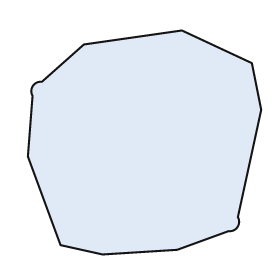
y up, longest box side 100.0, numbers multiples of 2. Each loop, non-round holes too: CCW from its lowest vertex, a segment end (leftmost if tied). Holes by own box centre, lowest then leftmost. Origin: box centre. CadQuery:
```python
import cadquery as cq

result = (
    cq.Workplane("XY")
    .moveTo(-18.0, -48.0)
    .lineTo(14.0, -46.0)
    .lineTo(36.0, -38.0)
    .threePointArc((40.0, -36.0), (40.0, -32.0))
    .lineTo(50.0, 14.0)
    .lineTo(46.0, 34.0)
    .lineTo(16.0, 48.0)
    .lineTo(-26.0, 42.0)
    .lineTo(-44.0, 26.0)
    .threePointArc((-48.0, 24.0), (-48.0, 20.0))
    .lineTo(-50.0, -6.0)
    .lineTo(-36.0, -44.0)
    .close()
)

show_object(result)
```